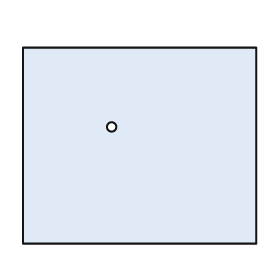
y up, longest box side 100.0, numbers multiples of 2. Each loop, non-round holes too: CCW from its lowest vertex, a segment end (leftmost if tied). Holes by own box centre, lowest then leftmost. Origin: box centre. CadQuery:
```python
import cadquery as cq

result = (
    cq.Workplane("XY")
    .moveTo(-50.0, -42.0)
    .lineTo(50.0, -42.0)
    .lineTo(50.0, 42.0)
    .lineTo(-50.0, 42.0)
    .close()
    .moveTo(-12.0, 8.0)
    .circle(2.0)
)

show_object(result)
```